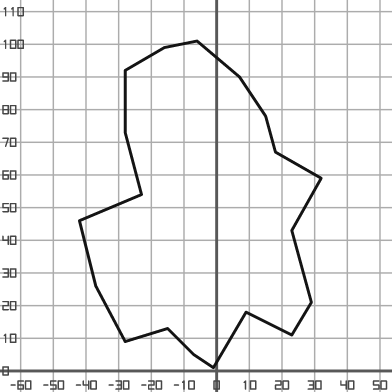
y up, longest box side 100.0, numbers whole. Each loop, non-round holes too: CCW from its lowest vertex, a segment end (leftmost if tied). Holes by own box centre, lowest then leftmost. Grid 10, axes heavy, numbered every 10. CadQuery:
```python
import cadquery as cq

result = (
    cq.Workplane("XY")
    .moveTo(-1.0, 1.0)
    .lineTo(9.0, 18.0)
    .lineTo(23.0, 11.0)
    .lineTo(29.0, 21.0)
    .lineTo(23.0, 43.0)
    .lineTo(32.0, 59.0)
    .lineTo(18.0, 67.0)
    .lineTo(15.0, 78.0)
    .lineTo(7.0, 90.0)
    .lineTo(-6.0, 101.0)
    .lineTo(-16.0, 99.0)
    .lineTo(-28.0, 92.0)
    .lineTo(-28.0, 73.0)
    .lineTo(-23.0, 54.0)
    .lineTo(-42.0, 46.0)
    .lineTo(-37.0, 26.0)
    .lineTo(-28.0, 9.0)
    .lineTo(-15.0, 13.0)
    .lineTo(-7.0, 5.0)
    .close()
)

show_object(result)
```